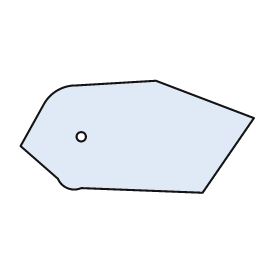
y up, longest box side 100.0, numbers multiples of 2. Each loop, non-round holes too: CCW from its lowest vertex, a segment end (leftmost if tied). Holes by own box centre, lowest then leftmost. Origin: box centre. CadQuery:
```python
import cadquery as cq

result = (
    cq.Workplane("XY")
    .moveTo(28.0, -24.0)
    .lineTo(50.0, 8.0)
    .lineTo(8.0, 24.0)
    .lineTo(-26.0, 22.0)
    .threePointArc((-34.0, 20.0), (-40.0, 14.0))
    .lineTo(-50.0, -4.0)
    .lineTo(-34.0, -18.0)
    .threePointArc((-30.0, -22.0), (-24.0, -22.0))
    .close()
    .moveTo(-24.0, 0.0)
    .circle(2.0)
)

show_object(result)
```